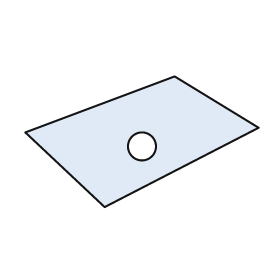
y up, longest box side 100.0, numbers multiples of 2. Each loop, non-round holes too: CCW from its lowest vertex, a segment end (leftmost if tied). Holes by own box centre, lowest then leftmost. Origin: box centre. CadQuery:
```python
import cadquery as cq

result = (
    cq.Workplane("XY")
    .moveTo(-16.0, -28.0)
    .lineTo(50.0, 6.0)
    .lineTo(14.0, 28.0)
    .lineTo(-50.0, 4.0)
    .close()
    .moveTo(0.0, -2.0)
    .circle(6.0)
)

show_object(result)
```